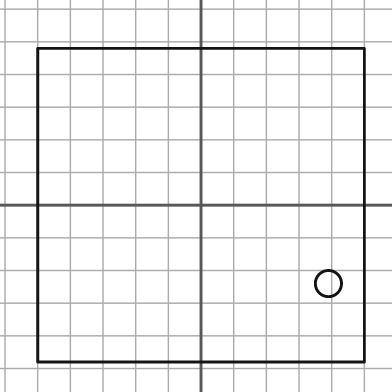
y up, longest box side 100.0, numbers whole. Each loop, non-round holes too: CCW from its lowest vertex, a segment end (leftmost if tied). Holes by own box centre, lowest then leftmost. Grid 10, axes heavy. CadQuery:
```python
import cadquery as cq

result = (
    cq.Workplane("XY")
    .moveTo(-50.0, -48.0)
    .lineTo(50.0, -48.0)
    .lineTo(50.0, 48.0)
    .lineTo(-50.0, 48.0)
    .close()
    .moveTo(39.0, -24.0)
    .circle(4.0)
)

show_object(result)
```